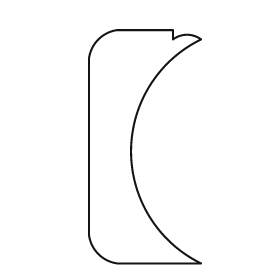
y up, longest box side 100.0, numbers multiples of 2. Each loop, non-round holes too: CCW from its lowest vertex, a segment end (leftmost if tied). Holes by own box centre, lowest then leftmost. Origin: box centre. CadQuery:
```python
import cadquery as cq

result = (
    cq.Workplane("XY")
    .moveTo(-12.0, -50.0)
    .lineTo(24.0, -50.0)
    .threePointArc((-6.0, -2.0), (24.0, 46.0))
    .threePointArc((18.0, 48.0), (12.0, 46.0))
    .lineTo(12.0, 50.0)
    .lineTo(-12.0, 50.0)
    .threePointArc((-20.0, 46.0), (-24.0, 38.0))
    .lineTo(-24.0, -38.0)
    .threePointArc((-20.0, -46.0), (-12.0, -50.0))
    .close()
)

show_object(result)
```